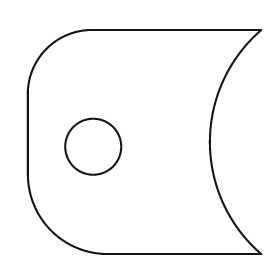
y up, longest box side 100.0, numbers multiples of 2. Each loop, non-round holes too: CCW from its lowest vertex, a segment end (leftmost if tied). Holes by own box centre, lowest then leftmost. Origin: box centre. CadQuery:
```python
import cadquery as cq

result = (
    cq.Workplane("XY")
    .moveTo(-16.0, -48.0)
    .lineTo(50.0, -48.0)
    .threePointArc((28.0, 0.0), (50.0, 48.0))
    .lineTo(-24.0, 48.0)
    .threePointArc((-42.0, 40.0), (-50.0, 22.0))
    .lineTo(-50.0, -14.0)
    .threePointArc((-40.0, -38.0), (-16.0, -48.0))
    .close()
    .moveTo(-22.0, -2.0)
    .circle(12.0)
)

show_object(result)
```